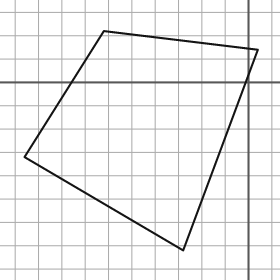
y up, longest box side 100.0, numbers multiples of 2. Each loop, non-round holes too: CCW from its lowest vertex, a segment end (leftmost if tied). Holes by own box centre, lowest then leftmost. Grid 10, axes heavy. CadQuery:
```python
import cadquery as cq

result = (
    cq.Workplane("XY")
    .moveTo(-28.0, -72.0)
    .lineTo(4.0, 14.0)
    .lineTo(-62.0, 22.0)
    .lineTo(-96.0, -32.0)
    .close()
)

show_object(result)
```